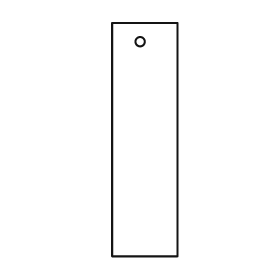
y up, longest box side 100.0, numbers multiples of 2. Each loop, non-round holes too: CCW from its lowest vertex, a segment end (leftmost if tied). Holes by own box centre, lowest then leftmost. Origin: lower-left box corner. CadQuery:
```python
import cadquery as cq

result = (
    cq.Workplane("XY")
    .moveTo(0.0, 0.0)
    .lineTo(28.0, 0.0)
    .lineTo(28.0, 100.0)
    .lineTo(0.0, 100.0)
    .close()
    .moveTo(12.0, 92.0)
    .circle(2.0)
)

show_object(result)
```